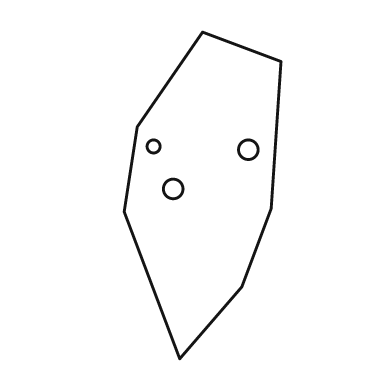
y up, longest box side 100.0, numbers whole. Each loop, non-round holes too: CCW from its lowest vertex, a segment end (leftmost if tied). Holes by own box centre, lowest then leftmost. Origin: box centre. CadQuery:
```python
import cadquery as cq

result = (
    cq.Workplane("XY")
    .moveTo(-7.0, -50.0)
    .lineTo(12.0, -28.0)
    .lineTo(21.0, -4.0)
    .lineTo(24.0, 41.0)
    .lineTo(0.0, 50.0)
    .lineTo(-20.0, 21.0)
    .lineTo(-24.0, -5.0)
    .close()
    .moveTo(-9.0, 2.0)
    .circle(3.0)
    .moveTo(14.0, 14.0)
    .circle(3.0)
    .moveTo(-15.0, 15.0)
    .circle(2.0)
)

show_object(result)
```